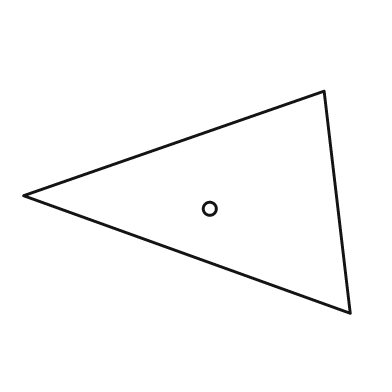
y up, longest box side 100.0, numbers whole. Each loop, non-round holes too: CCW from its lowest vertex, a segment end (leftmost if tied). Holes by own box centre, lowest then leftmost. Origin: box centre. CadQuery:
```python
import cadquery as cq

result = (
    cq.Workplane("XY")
    .moveTo(50.0, -34.0)
    .lineTo(42.0, 34.0)
    .lineTo(-50.0, 2.0)
    .close()
    .moveTo(7.0, -2.0)
    .circle(2.0)
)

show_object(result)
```